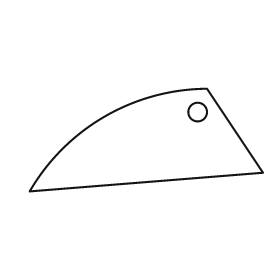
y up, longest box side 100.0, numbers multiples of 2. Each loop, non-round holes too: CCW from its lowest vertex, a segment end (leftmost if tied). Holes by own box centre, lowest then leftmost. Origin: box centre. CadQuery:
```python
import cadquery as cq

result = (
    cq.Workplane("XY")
    .moveTo(-50.0, -22.0)
    .lineTo(50.0, -14.0)
    .lineTo(26.0, 22.0)
    .threePointArc((-18.0, 10.0), (-50.0, -22.0))
    .close()
    .moveTo(22.0, 12.0)
    .circle(4.0)
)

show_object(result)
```